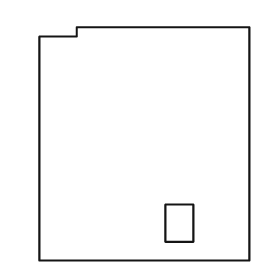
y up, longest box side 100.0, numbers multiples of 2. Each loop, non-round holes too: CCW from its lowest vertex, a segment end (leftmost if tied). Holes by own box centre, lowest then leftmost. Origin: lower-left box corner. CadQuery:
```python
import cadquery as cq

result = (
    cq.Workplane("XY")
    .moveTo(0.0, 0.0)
    .lineTo(90.0, 0.0)
    .lineTo(90.0, 100.0)
    .lineTo(16.0, 100.0)
    .lineTo(16.0, 96.0)
    .lineTo(0.0, 96.0)
    .close()
    .moveTo(54.0, 8.0)
    .lineTo(66.0, 8.0)
    .lineTo(66.0, 24.0)
    .lineTo(54.0, 24.0)
    .close()
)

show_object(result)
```